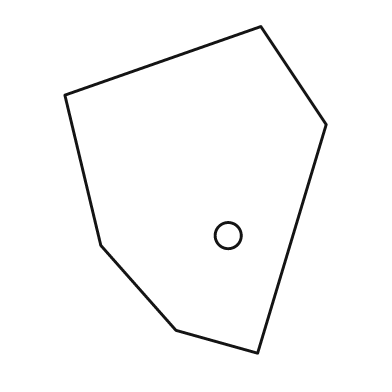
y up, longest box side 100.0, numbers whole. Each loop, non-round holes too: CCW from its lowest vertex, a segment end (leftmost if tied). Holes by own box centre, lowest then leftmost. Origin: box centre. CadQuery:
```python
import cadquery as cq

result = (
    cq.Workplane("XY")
    .moveTo(19.0, -50.0)
    .lineTo(40.0, 20.0)
    .lineTo(20.0, 50.0)
    .lineTo(-40.0, 29.0)
    .lineTo(-29.0, -17.0)
    .lineTo(-6.0, -43.0)
    .close()
    .moveTo(10.0, -14.0)
    .circle(4.0)
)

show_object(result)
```